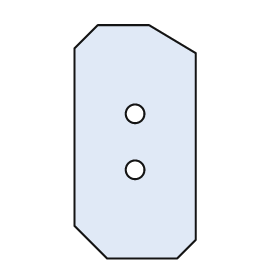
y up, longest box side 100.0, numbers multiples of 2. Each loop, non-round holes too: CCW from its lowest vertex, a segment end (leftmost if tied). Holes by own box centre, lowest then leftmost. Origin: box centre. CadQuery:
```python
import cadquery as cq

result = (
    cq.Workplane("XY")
    .moveTo(-12.0, -50.0)
    .lineTo(18.0, -50.0)
    .lineTo(26.0, -42.0)
    .lineTo(26.0, 38.0)
    .lineTo(6.0, 50.0)
    .lineTo(-16.0, 50.0)
    .lineTo(-26.0, 40.0)
    .lineTo(-26.0, -36.0)
    .close()
    .moveTo(0.0, -12.0)
    .circle(4.0)
    .moveTo(0.0, 12.0)
    .circle(4.0)
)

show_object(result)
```